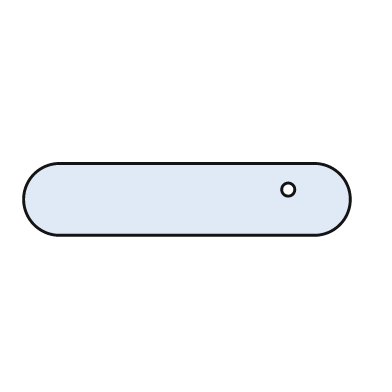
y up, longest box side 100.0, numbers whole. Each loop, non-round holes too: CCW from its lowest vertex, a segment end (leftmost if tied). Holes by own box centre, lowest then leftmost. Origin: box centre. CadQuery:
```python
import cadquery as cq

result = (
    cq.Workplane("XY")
    .moveTo(-39.0, -11.0)
    .lineTo(39.0, -11.0)
    .threePointArc((50.0, 0.0), (39.0, 11.0))
    .lineTo(-39.0, 11.0)
    .threePointArc((-50.0, 0.0), (-39.0, -11.0))
    .close()
    .moveTo(31.0, 3.0)
    .circle(2.0)
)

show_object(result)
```